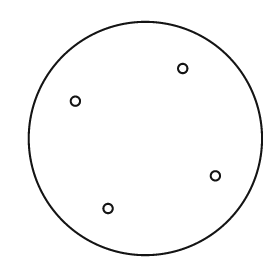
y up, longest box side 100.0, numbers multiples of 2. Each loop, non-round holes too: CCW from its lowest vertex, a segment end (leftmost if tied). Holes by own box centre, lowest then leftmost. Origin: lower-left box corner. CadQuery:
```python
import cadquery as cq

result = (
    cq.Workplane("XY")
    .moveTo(50.0, 50.0)
    .circle(50.0)
    .moveTo(34.0, 20.0)
    .circle(2.0)
    .moveTo(80.0, 34.0)
    .circle(2.0)
    .moveTo(20.0, 66.0)
    .circle(2.0)
    .moveTo(66.0, 80.0)
    .circle(2.0)
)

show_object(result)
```